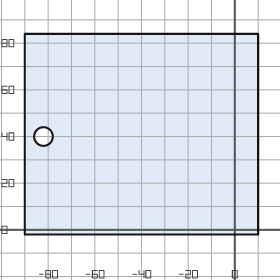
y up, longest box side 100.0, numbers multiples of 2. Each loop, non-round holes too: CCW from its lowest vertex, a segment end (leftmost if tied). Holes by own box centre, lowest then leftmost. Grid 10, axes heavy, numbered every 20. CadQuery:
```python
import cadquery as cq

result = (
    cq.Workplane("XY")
    .moveTo(-90.0, -2.0)
    .lineTo(10.0, -2.0)
    .lineTo(10.0, 84.0)
    .lineTo(-90.0, 84.0)
    .close()
    .moveTo(-82.0, 40.0)
    .circle(4.0)
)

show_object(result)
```